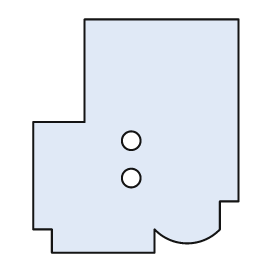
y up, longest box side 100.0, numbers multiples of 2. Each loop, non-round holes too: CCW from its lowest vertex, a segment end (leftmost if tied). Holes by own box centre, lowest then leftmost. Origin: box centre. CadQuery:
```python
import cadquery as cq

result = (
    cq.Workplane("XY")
    .moveTo(-36.0, -50.0)
    .lineTo(8.0, -50.0)
    .lineTo(8.0, -40.0)
    .threePointArc((22.0, -46.0), (36.0, -40.0))
    .lineTo(36.0, -28.0)
    .lineTo(44.0, -28.0)
    .lineTo(44.0, 50.0)
    .lineTo(-22.0, 50.0)
    .lineTo(-22.0, 6.0)
    .lineTo(-44.0, 6.0)
    .lineTo(-44.0, -40.0)
    .lineTo(-36.0, -40.0)
    .close()
    .moveTo(-2.0, -18.0)
    .circle(4.0)
    .moveTo(-2.0, -2.0)
    .circle(4.0)
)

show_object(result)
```